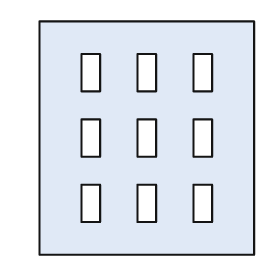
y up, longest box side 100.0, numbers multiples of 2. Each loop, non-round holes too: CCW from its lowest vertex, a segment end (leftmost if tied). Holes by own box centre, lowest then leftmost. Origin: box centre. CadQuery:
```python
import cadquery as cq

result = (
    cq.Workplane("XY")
    .moveTo(-46.0, -50.0)
    .lineTo(46.0, -50.0)
    .lineTo(46.0, 50.0)
    .lineTo(-46.0, 50.0)
    .close()
    .moveTo(-28.0, -36.0)
    .lineTo(-20.0, -36.0)
    .lineTo(-20.0, -20.0)
    .lineTo(-28.0, -20.0)
    .close()
    .moveTo(-4.0, -36.0)
    .lineTo(4.0, -36.0)
    .lineTo(4.0, -20.0)
    .lineTo(-4.0, -20.0)
    .close()
    .moveTo(20.0, -36.0)
    .lineTo(28.0, -36.0)
    .lineTo(28.0, -20.0)
    .lineTo(20.0, -20.0)
    .close()
    .moveTo(-28.0, -8.0)
    .lineTo(-20.0, -8.0)
    .lineTo(-20.0, 8.0)
    .lineTo(-28.0, 8.0)
    .close()
    .moveTo(-4.0, -8.0)
    .lineTo(4.0, -8.0)
    .lineTo(4.0, 8.0)
    .lineTo(-4.0, 8.0)
    .close()
    .moveTo(20.0, -8.0)
    .lineTo(28.0, -8.0)
    .lineTo(28.0, 8.0)
    .lineTo(20.0, 8.0)
    .close()
    .moveTo(-28.0, 20.0)
    .lineTo(-20.0, 20.0)
    .lineTo(-20.0, 36.0)
    .lineTo(-28.0, 36.0)
    .close()
    .moveTo(-4.0, 20.0)
    .lineTo(4.0, 20.0)
    .lineTo(4.0, 36.0)
    .lineTo(-4.0, 36.0)
    .close()
    .moveTo(20.0, 20.0)
    .lineTo(28.0, 20.0)
    .lineTo(28.0, 36.0)
    .lineTo(20.0, 36.0)
    .close()
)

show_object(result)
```